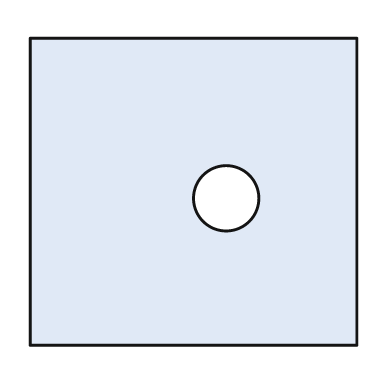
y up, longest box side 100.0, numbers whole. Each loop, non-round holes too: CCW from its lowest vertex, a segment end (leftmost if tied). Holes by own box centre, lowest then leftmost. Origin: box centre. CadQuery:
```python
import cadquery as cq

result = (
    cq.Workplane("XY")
    .moveTo(-50.0, -47.0)
    .lineTo(50.0, -47.0)
    .lineTo(50.0, 47.0)
    .lineTo(-50.0, 47.0)
    .close()
    .moveTo(10.0, -2.0)
    .circle(10.0)
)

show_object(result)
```